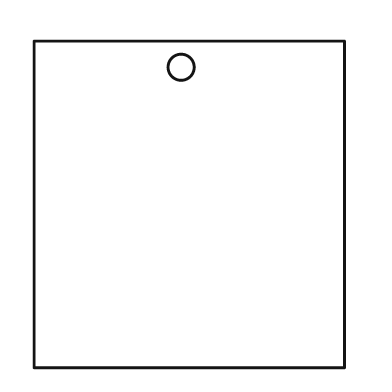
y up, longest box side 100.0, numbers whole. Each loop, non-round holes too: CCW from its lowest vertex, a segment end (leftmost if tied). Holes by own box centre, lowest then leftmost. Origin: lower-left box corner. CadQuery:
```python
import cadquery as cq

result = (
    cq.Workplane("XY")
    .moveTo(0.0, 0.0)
    .lineTo(95.0, 0.0)
    .lineTo(95.0, 100.0)
    .lineTo(0.0, 100.0)
    .close()
    .moveTo(45.0, 92.0)
    .circle(4.0)
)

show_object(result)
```